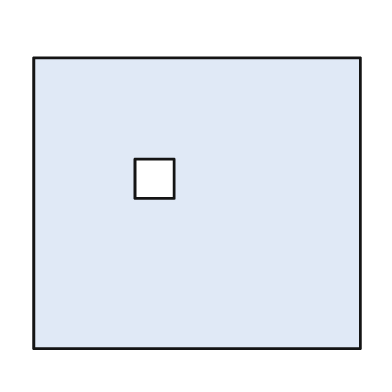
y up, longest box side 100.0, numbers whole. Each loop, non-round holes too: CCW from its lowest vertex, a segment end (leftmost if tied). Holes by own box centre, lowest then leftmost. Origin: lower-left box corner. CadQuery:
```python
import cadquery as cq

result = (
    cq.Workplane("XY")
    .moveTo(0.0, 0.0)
    .lineTo(100.0, 0.0)
    .lineTo(100.0, 89.0)
    .lineTo(0.0, 89.0)
    .close()
    .moveTo(31.0, 46.0)
    .lineTo(43.0, 46.0)
    .lineTo(43.0, 58.0)
    .lineTo(31.0, 58.0)
    .close()
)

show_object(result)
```